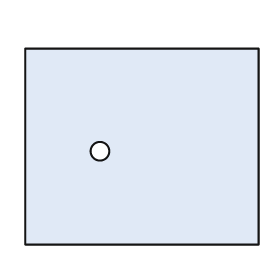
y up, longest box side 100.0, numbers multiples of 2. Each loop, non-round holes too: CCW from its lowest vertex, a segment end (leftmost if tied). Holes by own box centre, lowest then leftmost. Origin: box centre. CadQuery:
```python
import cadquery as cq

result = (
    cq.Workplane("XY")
    .moveTo(-50.0, -42.0)
    .lineTo(50.0, -42.0)
    .lineTo(50.0, 42.0)
    .lineTo(-50.0, 42.0)
    .close()
    .moveTo(-18.0, -2.0)
    .circle(4.0)
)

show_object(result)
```